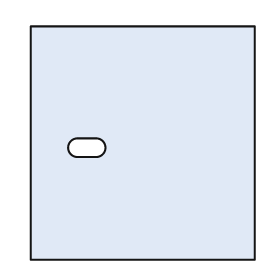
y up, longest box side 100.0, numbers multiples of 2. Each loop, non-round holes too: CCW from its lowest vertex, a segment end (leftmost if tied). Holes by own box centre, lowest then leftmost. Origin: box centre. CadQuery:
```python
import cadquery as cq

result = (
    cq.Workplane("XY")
    .moveTo(-48.0, -50.0)
    .lineTo(48.0, -50.0)
    .lineTo(48.0, 50.0)
    .lineTo(-48.0, 50.0)
    .close()
    .moveTo(-28.0, -6.0)
    .lineTo(-20.0, -6.0)
    .threePointArc((-16.0, -2.0), (-20.0, 2.0))
    .lineTo(-28.0, 2.0)
    .threePointArc((-32.0, -2.0), (-28.0, -6.0))
    .close()
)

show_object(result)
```